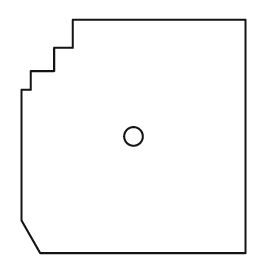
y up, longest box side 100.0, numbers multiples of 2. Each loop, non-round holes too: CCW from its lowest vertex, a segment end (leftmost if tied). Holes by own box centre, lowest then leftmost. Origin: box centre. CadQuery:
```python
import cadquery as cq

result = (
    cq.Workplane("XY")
    .moveTo(-40.0, -50.0)
    .lineTo(48.0, -50.0)
    .lineTo(48.0, 50.0)
    .lineTo(-26.0, 50.0)
    .lineTo(-26.0, 38.0)
    .lineTo(-34.0, 38.0)
    .lineTo(-34.0, 28.0)
    .lineTo(-44.0, 28.0)
    .lineTo(-44.0, 20.0)
    .lineTo(-48.0, 20.0)
    .lineTo(-48.0, -36.0)
    .close()
    .moveTo(0.0, 0.0)
    .circle(4.0)
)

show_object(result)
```